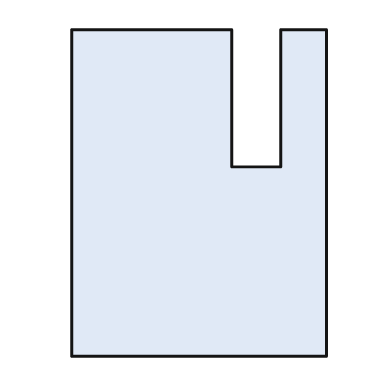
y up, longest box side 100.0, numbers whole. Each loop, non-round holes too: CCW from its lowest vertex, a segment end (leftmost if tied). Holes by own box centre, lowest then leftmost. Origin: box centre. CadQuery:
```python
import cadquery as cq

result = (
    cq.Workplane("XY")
    .moveTo(-39.0, -50.0)
    .lineTo(39.0, -50.0)
    .lineTo(39.0, 50.0)
    .lineTo(25.0, 50.0)
    .lineTo(25.0, 8.0)
    .lineTo(10.0, 8.0)
    .lineTo(10.0, 50.0)
    .lineTo(-39.0, 50.0)
    .close()
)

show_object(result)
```